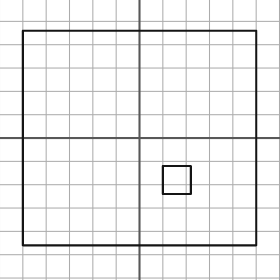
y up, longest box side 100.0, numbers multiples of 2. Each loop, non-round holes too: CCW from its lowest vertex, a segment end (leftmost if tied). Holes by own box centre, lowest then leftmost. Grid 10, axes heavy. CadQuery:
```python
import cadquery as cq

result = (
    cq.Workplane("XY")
    .moveTo(-50.0, -46.0)
    .lineTo(50.0, -46.0)
    .lineTo(50.0, 46.0)
    .lineTo(-50.0, 46.0)
    .close()
    .moveTo(10.0, -24.0)
    .lineTo(22.0, -24.0)
    .lineTo(22.0, -12.0)
    .lineTo(10.0, -12.0)
    .close()
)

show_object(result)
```